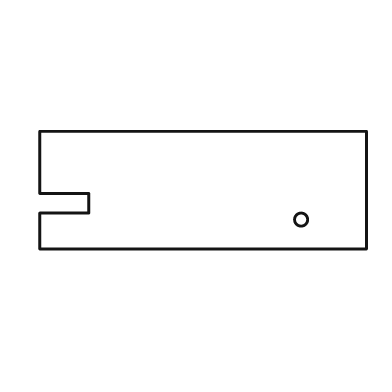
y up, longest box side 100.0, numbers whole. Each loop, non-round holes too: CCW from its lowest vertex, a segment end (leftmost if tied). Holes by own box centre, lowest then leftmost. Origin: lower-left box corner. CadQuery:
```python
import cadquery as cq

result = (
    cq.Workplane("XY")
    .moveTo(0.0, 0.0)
    .lineTo(100.0, 0.0)
    .lineTo(100.0, 36.0)
    .lineTo(0.0, 36.0)
    .lineTo(0.0, 17.0)
    .lineTo(15.0, 17.0)
    .lineTo(15.0, 11.0)
    .lineTo(0.0, 11.0)
    .close()
    .moveTo(80.0, 9.0)
    .circle(2.0)
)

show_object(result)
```